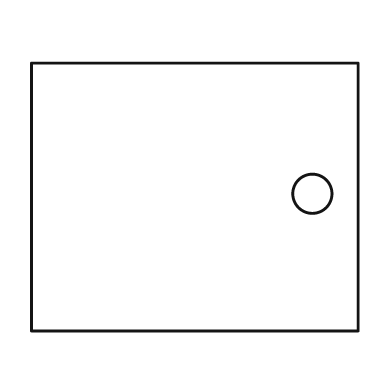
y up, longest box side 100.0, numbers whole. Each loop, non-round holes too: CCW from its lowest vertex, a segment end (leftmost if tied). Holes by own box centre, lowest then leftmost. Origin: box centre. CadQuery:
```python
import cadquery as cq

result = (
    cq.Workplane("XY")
    .moveTo(-50.0, -41.0)
    .lineTo(50.0, -41.0)
    .lineTo(50.0, 41.0)
    .lineTo(-50.0, 41.0)
    .close()
    .moveTo(36.0, 1.0)
    .circle(6.0)
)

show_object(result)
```